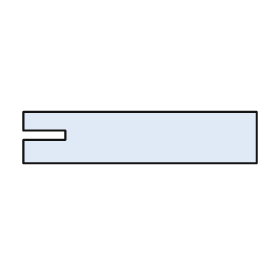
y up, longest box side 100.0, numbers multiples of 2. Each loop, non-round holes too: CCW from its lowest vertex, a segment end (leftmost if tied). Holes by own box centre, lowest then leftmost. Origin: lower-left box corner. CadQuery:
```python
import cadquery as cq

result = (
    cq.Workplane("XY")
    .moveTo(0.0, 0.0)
    .lineTo(100.0, 0.0)
    .lineTo(100.0, 22.0)
    .lineTo(0.0, 22.0)
    .lineTo(0.0, 14.0)
    .lineTo(18.0, 14.0)
    .lineTo(18.0, 10.0)
    .lineTo(0.0, 10.0)
    .close()
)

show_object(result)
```